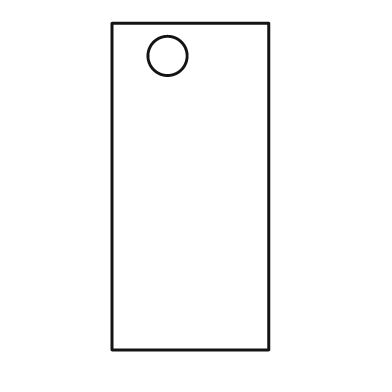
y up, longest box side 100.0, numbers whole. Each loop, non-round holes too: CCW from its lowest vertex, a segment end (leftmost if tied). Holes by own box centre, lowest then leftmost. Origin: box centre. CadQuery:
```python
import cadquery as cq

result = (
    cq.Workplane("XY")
    .moveTo(-24.0, -50.0)
    .lineTo(24.0, -50.0)
    .lineTo(24.0, 50.0)
    .lineTo(-24.0, 50.0)
    .close()
    .moveTo(-7.0, 40.0)
    .circle(6.0)
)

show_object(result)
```